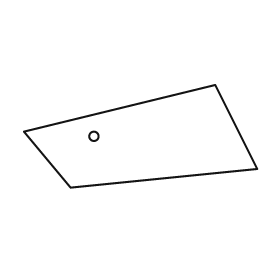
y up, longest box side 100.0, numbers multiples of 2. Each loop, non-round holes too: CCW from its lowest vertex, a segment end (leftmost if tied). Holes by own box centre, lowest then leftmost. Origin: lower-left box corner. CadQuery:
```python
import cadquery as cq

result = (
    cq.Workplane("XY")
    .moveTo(20.0, 0.0)
    .lineTo(100.0, 8.0)
    .lineTo(82.0, 44.0)
    .lineTo(0.0, 24.0)
    .close()
    .moveTo(30.0, 22.0)
    .circle(2.0)
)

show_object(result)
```